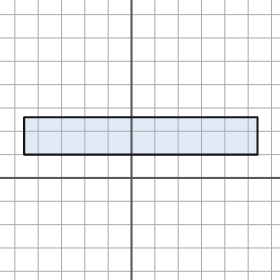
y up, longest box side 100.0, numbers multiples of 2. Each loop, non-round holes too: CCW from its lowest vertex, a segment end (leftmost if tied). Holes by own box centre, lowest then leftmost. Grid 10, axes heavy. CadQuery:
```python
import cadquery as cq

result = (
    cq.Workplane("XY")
    .moveTo(-46.0, 10.0)
    .lineTo(54.0, 10.0)
    .lineTo(54.0, 26.0)
    .lineTo(-46.0, 26.0)
    .close()
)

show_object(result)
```